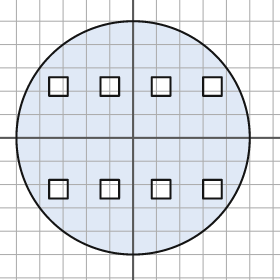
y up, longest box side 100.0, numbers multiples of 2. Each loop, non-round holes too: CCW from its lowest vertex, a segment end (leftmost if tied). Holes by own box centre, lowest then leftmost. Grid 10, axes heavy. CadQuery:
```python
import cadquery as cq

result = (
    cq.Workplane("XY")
    .moveTo(0.0, 0.0)
    .circle(50.0)
    .moveTo(-36.0, -26.0)
    .lineTo(-28.0, -26.0)
    .lineTo(-28.0, -18.0)
    .lineTo(-36.0, -18.0)
    .close()
    .moveTo(-14.0, -26.0)
    .lineTo(-6.0, -26.0)
    .lineTo(-6.0, -18.0)
    .lineTo(-14.0, -18.0)
    .close()
    .moveTo(8.0, -26.0)
    .lineTo(16.0, -26.0)
    .lineTo(16.0, -18.0)
    .lineTo(8.0, -18.0)
    .close()
    .moveTo(30.0, -26.0)
    .lineTo(38.0, -26.0)
    .lineTo(38.0, -18.0)
    .lineTo(30.0, -18.0)
    .close()
    .moveTo(-36.0, 18.0)
    .lineTo(-28.0, 18.0)
    .lineTo(-28.0, 26.0)
    .lineTo(-36.0, 26.0)
    .close()
    .moveTo(-14.0, 18.0)
    .lineTo(-6.0, 18.0)
    .lineTo(-6.0, 26.0)
    .lineTo(-14.0, 26.0)
    .close()
    .moveTo(8.0, 18.0)
    .lineTo(16.0, 18.0)
    .lineTo(16.0, 26.0)
    .lineTo(8.0, 26.0)
    .close()
    .moveTo(30.0, 18.0)
    .lineTo(38.0, 18.0)
    .lineTo(38.0, 26.0)
    .lineTo(30.0, 26.0)
    .close()
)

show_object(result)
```